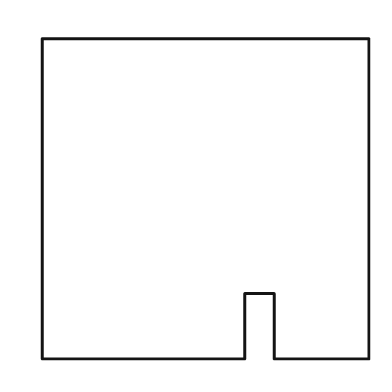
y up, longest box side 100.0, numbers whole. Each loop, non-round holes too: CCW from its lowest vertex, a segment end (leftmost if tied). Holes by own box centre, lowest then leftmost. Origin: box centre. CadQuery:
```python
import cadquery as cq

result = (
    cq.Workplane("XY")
    .moveTo(-50.0, -49.0)
    .lineTo(12.0, -49.0)
    .lineTo(12.0, -29.0)
    .lineTo(21.0, -29.0)
    .lineTo(21.0, -49.0)
    .lineTo(50.0, -49.0)
    .lineTo(50.0, 49.0)
    .lineTo(-50.0, 49.0)
    .close()
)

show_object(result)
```